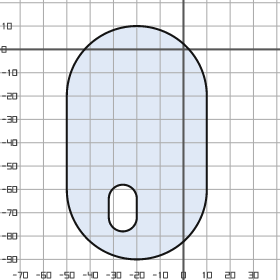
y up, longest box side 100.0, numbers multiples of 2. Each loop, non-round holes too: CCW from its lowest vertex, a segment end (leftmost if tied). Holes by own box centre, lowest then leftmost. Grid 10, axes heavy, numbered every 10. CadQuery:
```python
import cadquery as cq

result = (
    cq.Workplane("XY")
    .moveTo(-50.0, -60.0)
    .threePointArc((-20.0, -90.0), (10.0, -60.0))
    .lineTo(10.0, -20.0)
    .threePointArc((-20.0, 10.0), (-50.0, -20.0))
    .close()
    .moveTo(-32.0, -72.0)
    .threePointArc((-26.0, -78.0), (-20.0, -72.0))
    .lineTo(-20.0, -64.0)
    .threePointArc((-26.0, -58.0), (-32.0, -64.0))
    .close()
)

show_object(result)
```